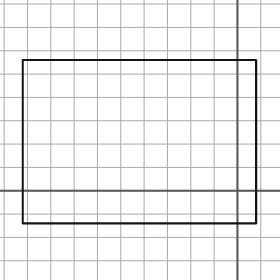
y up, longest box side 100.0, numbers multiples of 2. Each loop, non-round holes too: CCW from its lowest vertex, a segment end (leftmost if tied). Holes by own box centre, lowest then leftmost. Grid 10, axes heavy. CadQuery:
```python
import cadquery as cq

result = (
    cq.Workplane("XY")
    .moveTo(-92.0, -14.0)
    .lineTo(8.0, -14.0)
    .lineTo(8.0, 56.0)
    .lineTo(-92.0, 56.0)
    .close()
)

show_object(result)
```